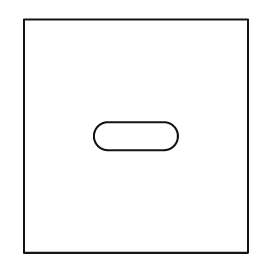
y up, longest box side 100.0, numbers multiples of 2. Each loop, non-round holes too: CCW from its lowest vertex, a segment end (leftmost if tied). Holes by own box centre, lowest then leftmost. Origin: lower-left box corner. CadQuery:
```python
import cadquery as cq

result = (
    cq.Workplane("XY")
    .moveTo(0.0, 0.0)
    .lineTo(96.0, 0.0)
    .lineTo(96.0, 100.0)
    .lineTo(0.0, 100.0)
    .close()
    .moveTo(36.0, 44.0)
    .lineTo(60.0, 44.0)
    .threePointArc((66.0, 50.0), (60.0, 56.0))
    .lineTo(36.0, 56.0)
    .threePointArc((30.0, 50.0), (36.0, 44.0))
    .close()
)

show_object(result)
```